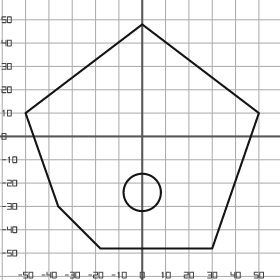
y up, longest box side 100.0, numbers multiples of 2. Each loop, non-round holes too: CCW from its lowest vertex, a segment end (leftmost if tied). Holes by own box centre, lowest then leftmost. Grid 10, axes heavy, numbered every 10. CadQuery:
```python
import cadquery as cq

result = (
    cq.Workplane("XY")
    .moveTo(-18.0, -48.0)
    .lineTo(30.0, -48.0)
    .lineTo(50.0, 10.0)
    .lineTo(0.0, 48.0)
    .lineTo(-50.0, 10.0)
    .lineTo(-36.0, -30.0)
    .close()
    .moveTo(0.0, -24.0)
    .circle(8.0)
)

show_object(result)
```